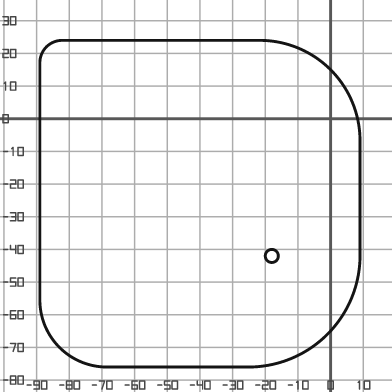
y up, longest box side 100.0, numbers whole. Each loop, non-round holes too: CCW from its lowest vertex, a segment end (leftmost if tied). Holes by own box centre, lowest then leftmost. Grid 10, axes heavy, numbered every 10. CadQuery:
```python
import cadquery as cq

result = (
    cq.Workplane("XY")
    .moveTo(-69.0, -76.0)
    .lineTo(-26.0, -76.0)
    .threePointArc((-1.0, -66.0), (9.0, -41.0))
    .lineTo(9.0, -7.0)
    .threePointArc((0.0, 15.0), (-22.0, 24.0))
    .lineTo(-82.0, 24.0)
    .threePointArc((-87.0, 22.0), (-89.0, 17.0))
    .lineTo(-89.0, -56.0)
    .threePointArc((-83.0, -70.0), (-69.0, -76.0))
    .close()
    .moveTo(-18.0, -42.0)
    .circle(2.0)
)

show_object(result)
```